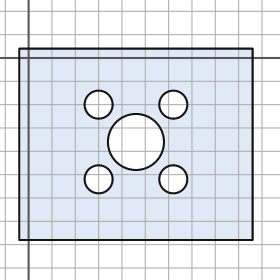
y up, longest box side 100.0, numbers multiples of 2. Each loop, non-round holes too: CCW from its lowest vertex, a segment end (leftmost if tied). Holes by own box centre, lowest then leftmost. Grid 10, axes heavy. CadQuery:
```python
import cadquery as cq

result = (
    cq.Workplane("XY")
    .moveTo(-4.0, -78.0)
    .lineTo(96.0, -78.0)
    .lineTo(96.0, 4.0)
    .lineTo(-4.0, 4.0)
    .close()
    .moveTo(30.0, -52.0)
    .circle(6.0)
    .moveTo(62.0, -52.0)
    .circle(6.0)
    .moveTo(46.0, -36.0)
    .circle(12.0)
    .moveTo(30.0, -20.0)
    .circle(6.0)
    .moveTo(62.0, -20.0)
    .circle(6.0)
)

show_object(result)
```